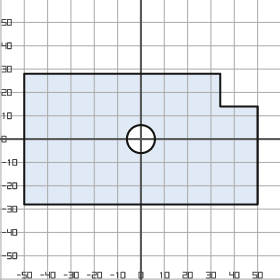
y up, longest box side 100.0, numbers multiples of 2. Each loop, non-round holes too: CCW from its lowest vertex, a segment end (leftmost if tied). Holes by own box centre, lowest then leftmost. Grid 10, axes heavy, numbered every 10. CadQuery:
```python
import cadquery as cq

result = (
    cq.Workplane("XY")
    .moveTo(-50.0, -28.0)
    .lineTo(50.0, -28.0)
    .lineTo(50.0, 14.0)
    .lineTo(34.0, 14.0)
    .lineTo(34.0, 28.0)
    .lineTo(-50.0, 28.0)
    .close()
    .moveTo(0.0, 0.0)
    .circle(6.0)
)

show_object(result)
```